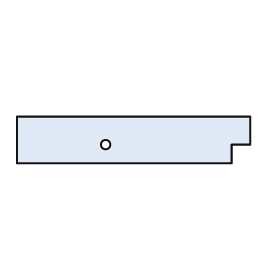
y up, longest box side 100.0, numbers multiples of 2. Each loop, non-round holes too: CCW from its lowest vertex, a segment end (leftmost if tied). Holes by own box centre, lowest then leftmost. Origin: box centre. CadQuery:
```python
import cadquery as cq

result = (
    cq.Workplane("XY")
    .moveTo(-50.0, -10.0)
    .lineTo(42.0, -10.0)
    .lineTo(42.0, -2.0)
    .lineTo(50.0, -2.0)
    .lineTo(50.0, 10.0)
    .lineTo(-50.0, 10.0)
    .close()
    .moveTo(-12.0, -2.0)
    .circle(2.0)
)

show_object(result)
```